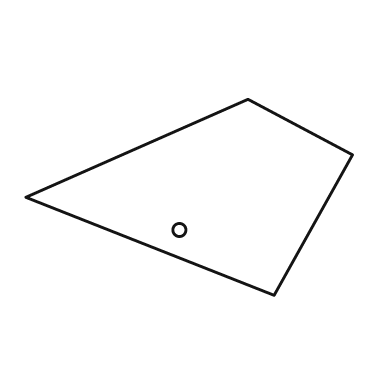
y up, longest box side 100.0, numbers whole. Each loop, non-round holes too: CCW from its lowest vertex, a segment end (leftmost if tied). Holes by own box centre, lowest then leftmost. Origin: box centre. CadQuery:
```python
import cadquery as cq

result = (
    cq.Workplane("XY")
    .moveTo(26.0, -30.0)
    .lineTo(50.0, 13.0)
    .lineTo(18.0, 30.0)
    .lineTo(-50.0, 0.0)
    .close()
    .moveTo(-3.0, -10.0)
    .circle(2.0)
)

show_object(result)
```